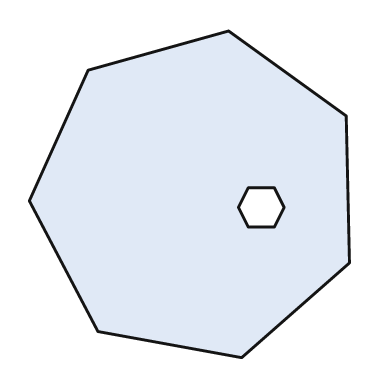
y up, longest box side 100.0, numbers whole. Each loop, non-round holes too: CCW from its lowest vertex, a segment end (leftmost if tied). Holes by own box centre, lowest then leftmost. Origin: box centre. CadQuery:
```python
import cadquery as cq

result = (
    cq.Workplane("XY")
    .moveTo(16.0, -50.0)
    .lineTo(49.0, -21.0)
    .lineTo(48.0, 24.0)
    .lineTo(12.0, 50.0)
    .lineTo(-31.0, 38.0)
    .lineTo(-49.0, -2.0)
    .lineTo(-28.0, -42.0)
    .close()
    .moveTo(18.0, -10.0)
    .lineTo(26.0, -10.0)
    .lineTo(29.0, -4.0)
    .lineTo(26.0, 2.0)
    .lineTo(18.0, 2.0)
    .lineTo(15.0, -4.0)
    .close()
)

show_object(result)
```